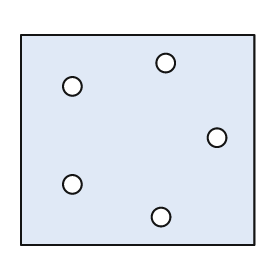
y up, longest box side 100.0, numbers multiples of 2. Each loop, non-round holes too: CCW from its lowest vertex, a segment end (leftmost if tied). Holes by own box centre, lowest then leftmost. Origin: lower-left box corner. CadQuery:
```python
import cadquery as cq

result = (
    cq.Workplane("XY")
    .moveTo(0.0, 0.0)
    .lineTo(100.0, 0.0)
    .lineTo(100.0, 90.0)
    .lineTo(0.0, 90.0)
    .close()
    .moveTo(60.0, 12.0)
    .circle(4.0)
    .moveTo(22.0, 26.0)
    .circle(4.0)
    .moveTo(84.0, 46.0)
    .circle(4.0)
    .moveTo(22.0, 68.0)
    .circle(4.0)
    .moveTo(62.0, 78.0)
    .circle(4.0)
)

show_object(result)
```